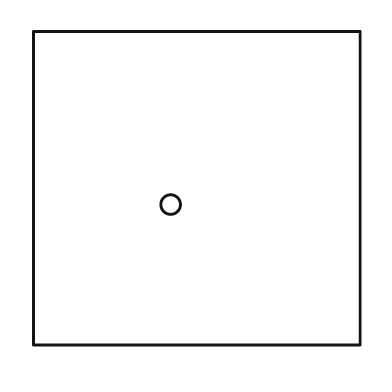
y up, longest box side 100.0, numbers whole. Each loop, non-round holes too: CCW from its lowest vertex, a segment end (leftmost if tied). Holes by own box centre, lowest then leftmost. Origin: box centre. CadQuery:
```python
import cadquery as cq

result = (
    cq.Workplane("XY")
    .moveTo(-50.0, -48.0)
    .lineTo(50.0, -48.0)
    .lineTo(50.0, 48.0)
    .lineTo(-50.0, 48.0)
    .close()
    .moveTo(-8.0, -5.0)
    .circle(3.0)
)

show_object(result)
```